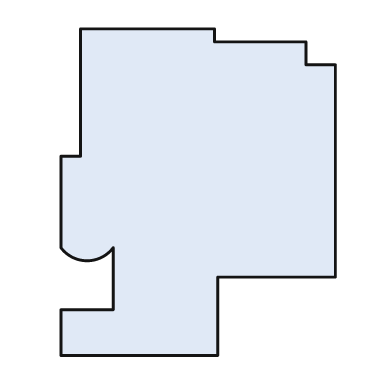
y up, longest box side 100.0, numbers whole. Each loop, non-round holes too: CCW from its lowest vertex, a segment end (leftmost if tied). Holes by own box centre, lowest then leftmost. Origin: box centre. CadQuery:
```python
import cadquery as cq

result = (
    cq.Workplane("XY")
    .moveTo(-42.0, -50.0)
    .lineTo(6.0, -50.0)
    .lineTo(6.0, -26.0)
    .lineTo(42.0, -26.0)
    .lineTo(42.0, 39.0)
    .lineTo(33.0, 39.0)
    .lineTo(33.0, 46.0)
    .lineTo(5.0, 46.0)
    .lineTo(5.0, 50.0)
    .lineTo(-36.0, 50.0)
    .lineTo(-36.0, 11.0)
    .lineTo(-42.0, 11.0)
    .lineTo(-42.0, -17.0)
    .threePointArc((-34.0, -21.0), (-26.0, -17.0))
    .lineTo(-26.0, -36.0)
    .lineTo(-42.0, -36.0)
    .close()
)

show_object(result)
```